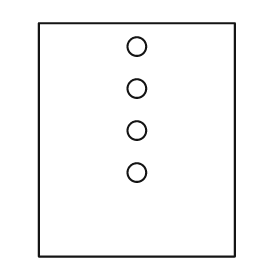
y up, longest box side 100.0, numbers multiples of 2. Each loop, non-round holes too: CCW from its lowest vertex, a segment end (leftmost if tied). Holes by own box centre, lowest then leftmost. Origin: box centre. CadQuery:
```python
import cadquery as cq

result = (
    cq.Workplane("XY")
    .moveTo(-42.0, -50.0)
    .lineTo(42.0, -50.0)
    .lineTo(42.0, 50.0)
    .lineTo(-42.0, 50.0)
    .close()
    .moveTo(0.0, -14.0)
    .circle(4.0)
    .moveTo(0.0, 4.0)
    .circle(4.0)
    .moveTo(0.0, 22.0)
    .circle(4.0)
    .moveTo(0.0, 40.0)
    .circle(4.0)
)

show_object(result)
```